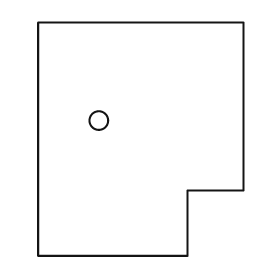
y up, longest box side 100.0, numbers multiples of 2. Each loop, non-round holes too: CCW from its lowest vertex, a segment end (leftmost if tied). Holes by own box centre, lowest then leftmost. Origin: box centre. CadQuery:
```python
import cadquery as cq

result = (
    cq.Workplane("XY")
    .moveTo(-44.0, -50.0)
    .lineTo(20.0, -50.0)
    .lineTo(20.0, -22.0)
    .lineTo(44.0, -22.0)
    .lineTo(44.0, 50.0)
    .lineTo(-44.0, 50.0)
    .close()
    .moveTo(-18.0, 8.0)
    .circle(4.0)
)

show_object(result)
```